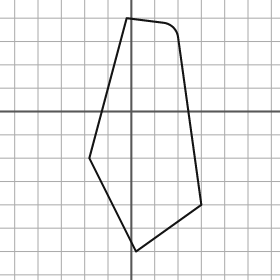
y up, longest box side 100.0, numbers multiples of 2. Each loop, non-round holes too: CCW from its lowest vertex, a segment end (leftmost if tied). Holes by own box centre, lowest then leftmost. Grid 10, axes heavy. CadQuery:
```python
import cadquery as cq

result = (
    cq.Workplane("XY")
    .moveTo(2.0, -60.0)
    .lineTo(30.0, -40.0)
    .lineTo(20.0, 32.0)
    .threePointArc((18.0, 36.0), (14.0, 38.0))
    .lineTo(-2.0, 40.0)
    .lineTo(-18.0, -20.0)
    .close()
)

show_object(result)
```